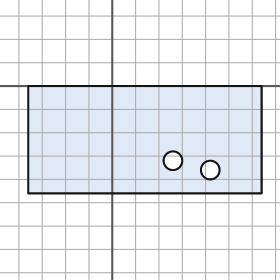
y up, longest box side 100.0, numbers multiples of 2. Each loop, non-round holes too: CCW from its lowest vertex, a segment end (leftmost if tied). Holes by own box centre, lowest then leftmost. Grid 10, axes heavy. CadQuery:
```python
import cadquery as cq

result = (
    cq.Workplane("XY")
    .moveTo(-36.0, -46.0)
    .lineTo(64.0, -46.0)
    .lineTo(64.0, 0.0)
    .lineTo(-36.0, 0.0)
    .close()
    .moveTo(42.0, -36.0)
    .circle(4.0)
    .moveTo(26.0, -32.0)
    .circle(4.0)
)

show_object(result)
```